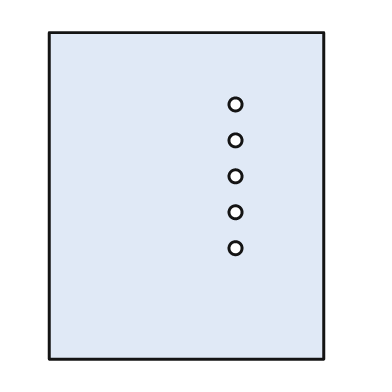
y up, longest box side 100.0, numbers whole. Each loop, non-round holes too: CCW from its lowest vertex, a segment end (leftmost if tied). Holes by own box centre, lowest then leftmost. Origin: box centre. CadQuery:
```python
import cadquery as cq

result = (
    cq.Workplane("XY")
    .moveTo(-42.0, -50.0)
    .lineTo(42.0, -50.0)
    .lineTo(42.0, 50.0)
    .lineTo(-42.0, 50.0)
    .close()
    .moveTo(15.0, -16.0)
    .circle(2.0)
    .moveTo(15.0, -5.0)
    .circle(2.0)
    .moveTo(15.0, 6.0)
    .circle(2.0)
    .moveTo(15.0, 17.0)
    .circle(2.0)
    .moveTo(15.0, 28.0)
    .circle(2.0)
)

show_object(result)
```